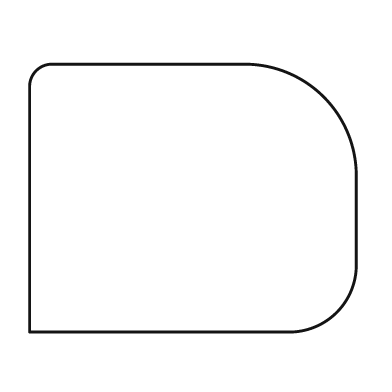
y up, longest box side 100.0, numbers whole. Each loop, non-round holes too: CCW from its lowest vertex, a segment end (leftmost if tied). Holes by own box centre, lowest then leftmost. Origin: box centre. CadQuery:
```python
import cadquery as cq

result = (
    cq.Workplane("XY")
    .moveTo(-50.0, -41.0)
    .lineTo(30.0, -41.0)
    .threePointArc((44.0, -35.0), (50.0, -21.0))
    .lineTo(50.0, 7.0)
    .threePointArc((40.0, 31.0), (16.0, 41.0))
    .lineTo(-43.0, 41.0)
    .threePointArc((-48.0, 39.0), (-50.0, 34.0))
    .close()
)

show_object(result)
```